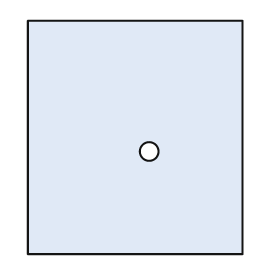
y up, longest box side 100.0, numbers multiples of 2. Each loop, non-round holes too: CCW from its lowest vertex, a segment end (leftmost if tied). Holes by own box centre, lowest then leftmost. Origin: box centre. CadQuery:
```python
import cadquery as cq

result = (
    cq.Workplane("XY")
    .moveTo(-46.0, -50.0)
    .lineTo(46.0, -50.0)
    .lineTo(46.0, 50.0)
    .lineTo(-46.0, 50.0)
    .close()
    .moveTo(6.0, -6.0)
    .circle(4.0)
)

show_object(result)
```